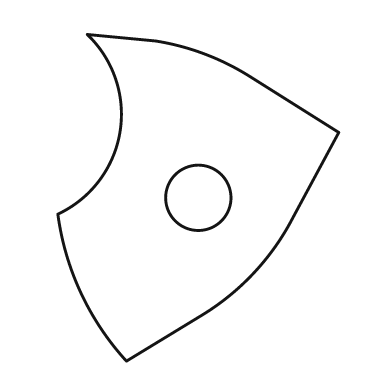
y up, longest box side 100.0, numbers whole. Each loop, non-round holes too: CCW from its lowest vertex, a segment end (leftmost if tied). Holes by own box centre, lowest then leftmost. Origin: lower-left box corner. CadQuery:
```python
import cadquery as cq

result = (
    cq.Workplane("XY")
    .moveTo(21.0, 0.0)
    .lineTo(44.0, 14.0)
    .threePointArc((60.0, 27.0), (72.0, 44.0))
    .lineTo(86.0, 70.0)
    .lineTo(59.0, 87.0)
    .threePointArc((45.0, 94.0), (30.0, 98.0))
    .lineTo(9.0, 100.0)
    .threePointArc((19.0, 70.0), (0.0, 45.0))
    .threePointArc((7.0, 21.0), (21.0, 0.0))
    .close()
    .moveTo(43.0, 50.0)
    .circle(10.0)
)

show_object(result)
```